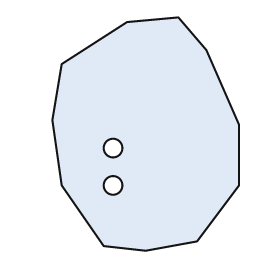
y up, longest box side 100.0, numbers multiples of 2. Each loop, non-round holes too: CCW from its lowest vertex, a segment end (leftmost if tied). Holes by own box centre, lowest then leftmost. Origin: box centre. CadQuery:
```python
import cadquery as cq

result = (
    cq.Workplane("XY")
    .moveTo(0.0, -50.0)
    .lineTo(22.0, -46.0)
    .lineTo(40.0, -22.0)
    .lineTo(40.0, 4.0)
    .lineTo(26.0, 36.0)
    .lineTo(14.0, 50.0)
    .lineTo(-8.0, 48.0)
    .lineTo(-36.0, 30.0)
    .lineTo(-40.0, 6.0)
    .lineTo(-36.0, -22.0)
    .lineTo(-18.0, -48.0)
    .close()
    .moveTo(-14.0, -22.0)
    .circle(4.0)
    .moveTo(-14.0, -6.0)
    .circle(4.0)
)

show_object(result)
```